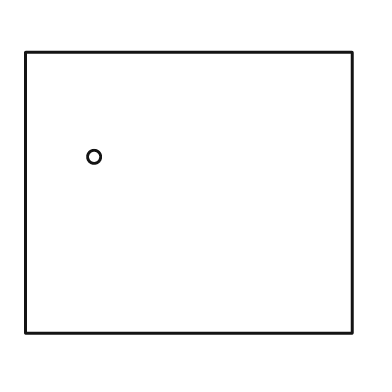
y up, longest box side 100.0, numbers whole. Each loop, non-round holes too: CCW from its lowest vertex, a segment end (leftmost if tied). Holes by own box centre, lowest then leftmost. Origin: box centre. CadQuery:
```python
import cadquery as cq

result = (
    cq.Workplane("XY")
    .moveTo(-50.0, -43.0)
    .lineTo(50.0, -43.0)
    .lineTo(50.0, 43.0)
    .lineTo(-50.0, 43.0)
    .close()
    .moveTo(-29.0, 11.0)
    .circle(2.0)
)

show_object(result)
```